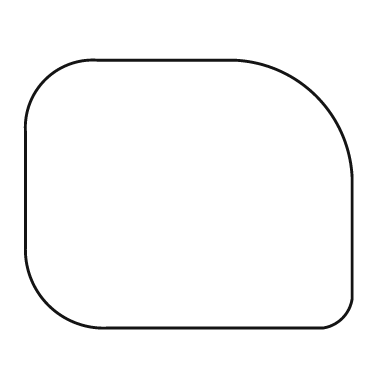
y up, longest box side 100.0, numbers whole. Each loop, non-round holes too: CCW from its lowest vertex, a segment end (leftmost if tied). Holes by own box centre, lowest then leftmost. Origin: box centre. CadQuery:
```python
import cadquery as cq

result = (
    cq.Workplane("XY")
    .moveTo(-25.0, -41.0)
    .lineTo(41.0, -41.0)
    .threePointArc((47.0, -38.0), (50.0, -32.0))
    .lineTo(50.0, 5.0)
    .threePointArc((39.0, 30.0), (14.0, 41.0))
    .lineTo(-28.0, 41.0)
    .threePointArc((-44.0, 35.0), (-50.0, 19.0))
    .lineTo(-50.0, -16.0)
    .threePointArc((-43.0, -34.0), (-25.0, -41.0))
    .close()
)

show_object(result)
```